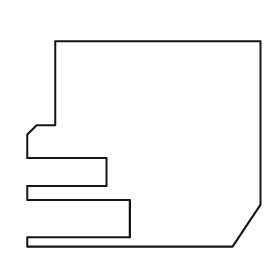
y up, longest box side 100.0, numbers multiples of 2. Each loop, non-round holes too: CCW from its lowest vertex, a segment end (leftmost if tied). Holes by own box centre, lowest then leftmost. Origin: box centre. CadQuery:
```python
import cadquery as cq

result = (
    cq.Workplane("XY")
    .moveTo(-50.0, -44.0)
    .lineTo(38.0, -44.0)
    .lineTo(50.0, -26.0)
    .lineTo(50.0, 44.0)
    .lineTo(-38.0, 44.0)
    .lineTo(-38.0, 8.0)
    .lineTo(-46.0, 8.0)
    .lineTo(-50.0, 4.0)
    .lineTo(-50.0, -6.0)
    .lineTo(-16.0, -6.0)
    .lineTo(-16.0, -18.0)
    .lineTo(-50.0, -18.0)
    .lineTo(-50.0, -24.0)
    .lineTo(-6.0, -24.0)
    .lineTo(-6.0, -40.0)
    .lineTo(-50.0, -40.0)
    .close()
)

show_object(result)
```